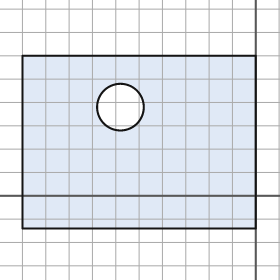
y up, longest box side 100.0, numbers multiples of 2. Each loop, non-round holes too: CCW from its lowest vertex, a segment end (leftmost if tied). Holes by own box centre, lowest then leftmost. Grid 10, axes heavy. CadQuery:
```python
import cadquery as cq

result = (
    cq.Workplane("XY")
    .moveTo(-100.0, -14.0)
    .lineTo(0.0, -14.0)
    .lineTo(0.0, 60.0)
    .lineTo(-100.0, 60.0)
    .close()
    .moveTo(-58.0, 38.0)
    .circle(10.0)
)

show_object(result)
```